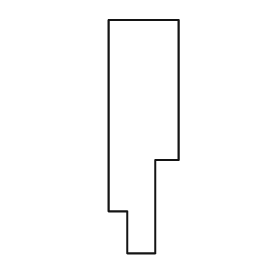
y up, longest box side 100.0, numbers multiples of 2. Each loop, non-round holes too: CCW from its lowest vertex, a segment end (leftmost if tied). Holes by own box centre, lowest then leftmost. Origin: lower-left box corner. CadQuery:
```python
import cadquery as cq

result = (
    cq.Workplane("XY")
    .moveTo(8.0, 0.0)
    .lineTo(20.0, 0.0)
    .lineTo(20.0, 40.0)
    .lineTo(30.0, 40.0)
    .lineTo(30.0, 100.0)
    .lineTo(0.0, 100.0)
    .lineTo(0.0, 18.0)
    .lineTo(8.0, 18.0)
    .close()
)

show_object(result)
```